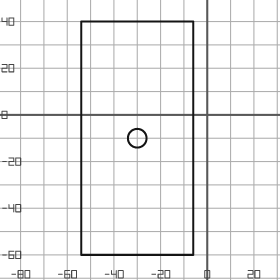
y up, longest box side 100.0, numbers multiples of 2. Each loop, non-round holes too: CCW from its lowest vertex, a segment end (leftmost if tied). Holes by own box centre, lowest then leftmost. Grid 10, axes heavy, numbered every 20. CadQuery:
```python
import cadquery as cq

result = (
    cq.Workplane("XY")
    .moveTo(-54.0, -60.0)
    .lineTo(-6.0, -60.0)
    .lineTo(-6.0, 40.0)
    .lineTo(-54.0, 40.0)
    .close()
    .moveTo(-30.0, -10.0)
    .circle(4.0)
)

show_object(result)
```